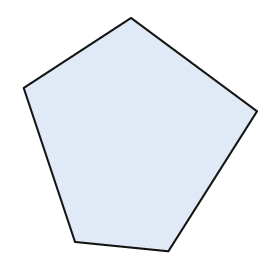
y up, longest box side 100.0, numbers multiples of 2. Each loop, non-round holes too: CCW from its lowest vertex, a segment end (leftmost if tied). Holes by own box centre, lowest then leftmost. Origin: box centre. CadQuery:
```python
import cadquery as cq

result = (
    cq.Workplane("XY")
    .moveTo(12.0, -50.0)
    .lineTo(50.0, 10.0)
    .lineTo(-4.0, 50.0)
    .lineTo(-50.0, 20.0)
    .lineTo(-28.0, -46.0)
    .close()
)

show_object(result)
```